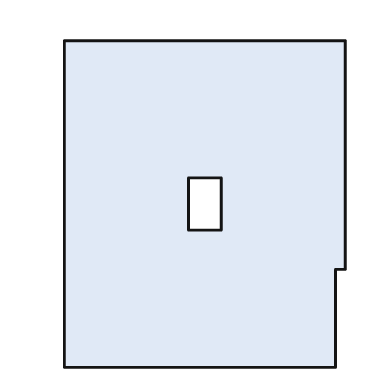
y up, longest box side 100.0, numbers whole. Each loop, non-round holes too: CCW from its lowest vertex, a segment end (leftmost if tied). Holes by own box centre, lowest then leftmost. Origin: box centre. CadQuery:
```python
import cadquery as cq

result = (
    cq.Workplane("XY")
    .moveTo(-43.0, -50.0)
    .lineTo(40.0, -50.0)
    .lineTo(40.0, -20.0)
    .lineTo(43.0, -20.0)
    .lineTo(43.0, 50.0)
    .lineTo(-43.0, 50.0)
    .close()
    .moveTo(-5.0, -8.0)
    .lineTo(5.0, -8.0)
    .lineTo(5.0, 8.0)
    .lineTo(-5.0, 8.0)
    .close()
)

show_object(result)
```